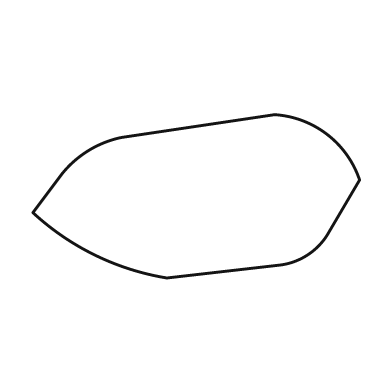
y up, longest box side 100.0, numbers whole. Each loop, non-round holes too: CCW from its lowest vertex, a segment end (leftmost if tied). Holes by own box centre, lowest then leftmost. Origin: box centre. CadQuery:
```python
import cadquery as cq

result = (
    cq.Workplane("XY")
    .moveTo(-9.0, -25.0)
    .lineTo(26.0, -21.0)
    .threePointArc((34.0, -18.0), (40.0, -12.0))
    .lineTo(50.0, 5.0)
    .threePointArc((40.0, 19.0), (24.0, 25.0))
    .lineTo(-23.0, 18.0)
    .threePointArc((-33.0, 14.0), (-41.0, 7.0))
    .lineTo(-50.0, -5.0)
    .threePointArc((-31.0, -18.0), (-9.0, -25.0))
    .close()
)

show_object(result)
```